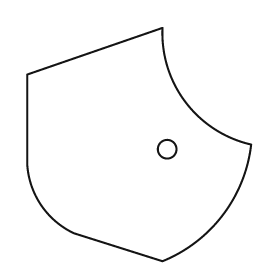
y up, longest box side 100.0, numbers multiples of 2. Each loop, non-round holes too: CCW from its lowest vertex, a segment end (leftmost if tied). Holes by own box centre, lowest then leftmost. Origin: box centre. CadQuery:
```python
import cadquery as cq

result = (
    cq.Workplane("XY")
    .moveTo(10.0, -50.0)
    .threePointArc((36.0, -30.0), (48.0, 0.0))
    .threePointArc((20.0, 18.0), (10.0, 50.0))
    .lineTo(-48.0, 30.0)
    .lineTo(-48.0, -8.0)
    .threePointArc((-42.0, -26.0), (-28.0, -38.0))
    .close()
    .moveTo(12.0, -2.0)
    .circle(4.0)
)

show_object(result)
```